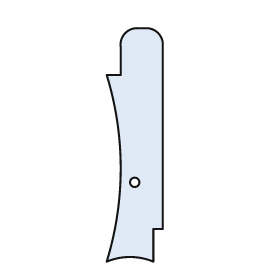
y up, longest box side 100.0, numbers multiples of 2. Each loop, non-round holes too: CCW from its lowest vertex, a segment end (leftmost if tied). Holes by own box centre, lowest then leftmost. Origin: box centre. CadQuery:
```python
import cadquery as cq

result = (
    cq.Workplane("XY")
    .moveTo(-12.0, -50.0)
    .threePointArc((-2.0, -48.0), (8.0, -50.0))
    .lineTo(8.0, -36.0)
    .lineTo(12.0, -36.0)
    .lineTo(12.0, 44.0)
    .threePointArc((10.0, 48.0), (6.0, 50.0))
    .lineTo(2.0, 50.0)
    .threePointArc((-4.0, 48.0), (-6.0, 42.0))
    .lineTo(-6.0, 30.0)
    .lineTo(-12.0, 30.0)
    .threePointArc((-6.0, -10.0), (-12.0, -50.0))
    .close()
    .moveTo(0.0, -16.0)
    .circle(2.0)
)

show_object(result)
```